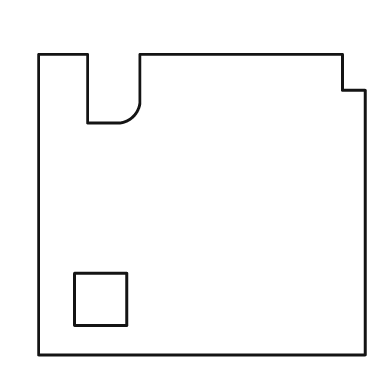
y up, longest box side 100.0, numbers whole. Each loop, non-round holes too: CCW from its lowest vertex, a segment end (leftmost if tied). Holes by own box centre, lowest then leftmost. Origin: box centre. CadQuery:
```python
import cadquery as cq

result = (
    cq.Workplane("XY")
    .moveTo(-50.0, -46.0)
    .lineTo(50.0, -46.0)
    .lineTo(50.0, 35.0)
    .lineTo(43.0, 35.0)
    .lineTo(43.0, 46.0)
    .lineTo(-19.0, 46.0)
    .lineTo(-19.0, 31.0)
    .threePointArc((-21.0, 27.0), (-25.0, 25.0))
    .lineTo(-35.0, 25.0)
    .lineTo(-35.0, 46.0)
    .lineTo(-50.0, 46.0)
    .close()
    .moveTo(-39.0, -37.0)
    .lineTo(-23.0, -37.0)
    .lineTo(-23.0, -21.0)
    .lineTo(-39.0, -21.0)
    .close()
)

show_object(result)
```